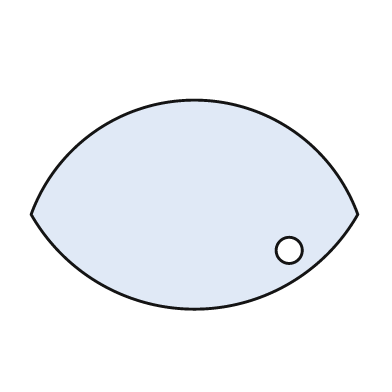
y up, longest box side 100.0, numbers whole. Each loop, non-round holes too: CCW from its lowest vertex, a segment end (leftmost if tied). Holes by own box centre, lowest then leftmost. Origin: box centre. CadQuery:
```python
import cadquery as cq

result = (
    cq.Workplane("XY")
    .moveTo(-50.0, -3.0)
    .threePointArc((0.0, -32.0), (50.0, -3.0))
    .threePointArc((0.0, 32.0), (-50.0, -3.0))
    .close()
    .moveTo(29.0, -14.0)
    .circle(4.0)
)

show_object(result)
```